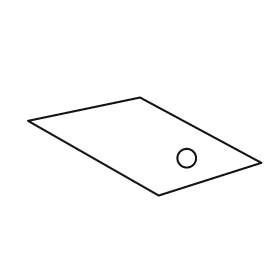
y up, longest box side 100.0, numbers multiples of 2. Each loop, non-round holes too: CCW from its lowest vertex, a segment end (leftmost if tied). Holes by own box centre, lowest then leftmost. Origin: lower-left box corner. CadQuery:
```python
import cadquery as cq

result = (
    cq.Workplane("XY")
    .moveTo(56.0, 0.0)
    .lineTo(100.0, 14.0)
    .lineTo(48.0, 42.0)
    .lineTo(0.0, 32.0)
    .close()
    .moveTo(68.0, 16.0)
    .circle(4.0)
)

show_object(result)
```